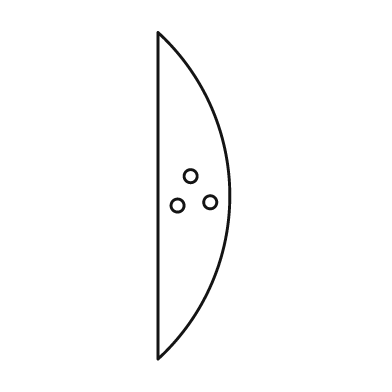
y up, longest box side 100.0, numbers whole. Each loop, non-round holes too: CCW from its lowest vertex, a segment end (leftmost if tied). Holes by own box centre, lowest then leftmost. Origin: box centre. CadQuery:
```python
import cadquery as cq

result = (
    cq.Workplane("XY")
    .moveTo(-11.0, -50.0)
    .threePointArc((11.0, 0.0), (-11.0, 50.0))
    .close()
    .moveTo(-5.0, -3.0)
    .circle(2.0)
    .moveTo(5.0, -2.0)
    .circle(2.0)
    .moveTo(-1.0, 6.0)
    .circle(2.0)
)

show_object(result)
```